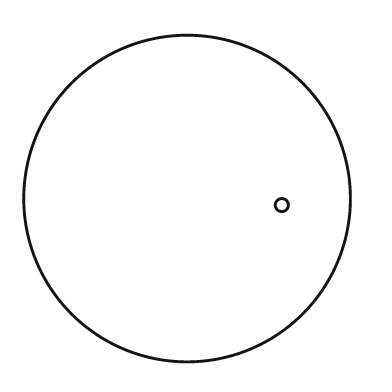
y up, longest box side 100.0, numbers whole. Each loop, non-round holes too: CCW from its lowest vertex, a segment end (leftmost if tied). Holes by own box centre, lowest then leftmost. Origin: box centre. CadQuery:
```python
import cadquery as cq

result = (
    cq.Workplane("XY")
    .moveTo(0.0, 0.0)
    .circle(50.0)
    .moveTo(29.0, -2.0)
    .circle(2.0)
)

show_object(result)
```